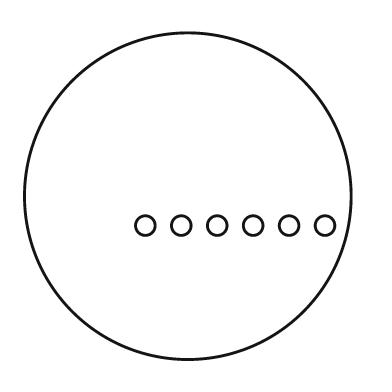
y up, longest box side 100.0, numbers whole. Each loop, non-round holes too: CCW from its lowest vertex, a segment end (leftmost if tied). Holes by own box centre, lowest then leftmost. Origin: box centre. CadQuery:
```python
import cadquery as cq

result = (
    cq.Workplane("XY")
    .moveTo(0.0, 0.0)
    .circle(50.0)
    .moveTo(-13.0, -9.0)
    .circle(3.0)
    .moveTo(-2.0, -9.0)
    .circle(3.0)
    .moveTo(9.0, -9.0)
    .circle(3.0)
    .moveTo(20.0, -9.0)
    .circle(3.0)
    .moveTo(31.0, -9.0)
    .circle(3.0)
    .moveTo(42.0, -9.0)
    .circle(3.0)
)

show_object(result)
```